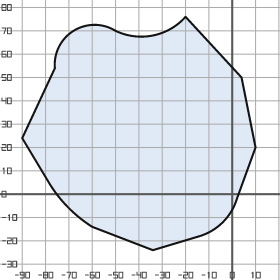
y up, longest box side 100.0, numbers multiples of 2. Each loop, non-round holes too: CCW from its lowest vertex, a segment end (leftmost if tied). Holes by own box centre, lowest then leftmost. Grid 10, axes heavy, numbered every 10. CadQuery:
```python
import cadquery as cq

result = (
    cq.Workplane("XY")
    .moveTo(-34.0, -24.0)
    .lineTo(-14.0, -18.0)
    .threePointArc((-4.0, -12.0), (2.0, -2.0))
    .lineTo(10.0, 20.0)
    .lineTo(4.0, 50.0)
    .lineTo(-20.0, 76.0)
    .threePointArc((-34.0, 68.0), (-50.0, 70.0))
    .threePointArc((-68.0, 70.0), (-76.0, 54.0))
    .lineTo(-90.0, 24.0)
    .lineTo(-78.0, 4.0)
    .threePointArc((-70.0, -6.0), (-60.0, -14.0))
    .close()
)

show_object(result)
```